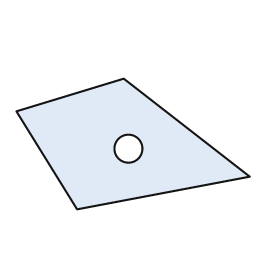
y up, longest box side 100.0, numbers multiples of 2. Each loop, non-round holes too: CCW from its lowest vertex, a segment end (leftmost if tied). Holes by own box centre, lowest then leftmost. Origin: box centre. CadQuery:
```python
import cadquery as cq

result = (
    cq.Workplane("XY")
    .moveTo(-24.0, -28.0)
    .lineTo(50.0, -14.0)
    .lineTo(-4.0, 28.0)
    .lineTo(-50.0, 14.0)
    .close()
    .moveTo(-2.0, -2.0)
    .circle(6.0)
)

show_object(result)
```